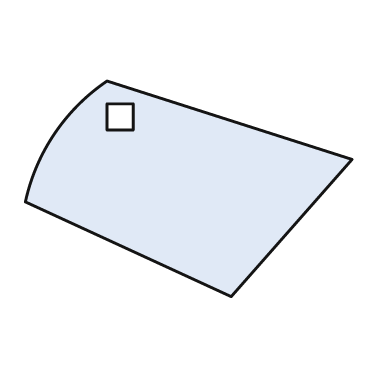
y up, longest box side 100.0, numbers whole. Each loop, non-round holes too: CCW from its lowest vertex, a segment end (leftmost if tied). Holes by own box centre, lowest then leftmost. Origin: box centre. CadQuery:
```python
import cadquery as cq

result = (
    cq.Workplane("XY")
    .moveTo(13.0, -33.0)
    .lineTo(50.0, 9.0)
    .lineTo(-25.0, 33.0)
    .threePointArc((-41.0, 17.0), (-50.0, -4.0))
    .close()
    .moveTo(-25.0, 18.0)
    .lineTo(-17.0, 18.0)
    .lineTo(-17.0, 26.0)
    .lineTo(-25.0, 26.0)
    .close()
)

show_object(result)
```